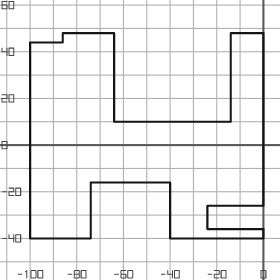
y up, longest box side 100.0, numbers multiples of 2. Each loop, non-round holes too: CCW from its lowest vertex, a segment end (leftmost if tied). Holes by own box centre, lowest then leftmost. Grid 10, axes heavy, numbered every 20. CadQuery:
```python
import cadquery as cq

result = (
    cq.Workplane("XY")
    .moveTo(-100.0, -40.0)
    .lineTo(-74.0, -40.0)
    .lineTo(-74.0, -16.0)
    .lineTo(-40.0, -16.0)
    .lineTo(-40.0, -40.0)
    .lineTo(0.0, -40.0)
    .lineTo(0.0, -36.0)
    .lineTo(-24.0, -36.0)
    .lineTo(-24.0, -26.0)
    .lineTo(0.0, -26.0)
    .lineTo(0.0, 48.0)
    .lineTo(-14.0, 48.0)
    .lineTo(-14.0, 10.0)
    .lineTo(-64.0, 10.0)
    .lineTo(-64.0, 48.0)
    .lineTo(-86.0, 48.0)
    .lineTo(-86.0, 44.0)
    .lineTo(-100.0, 44.0)
    .close()
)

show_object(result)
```